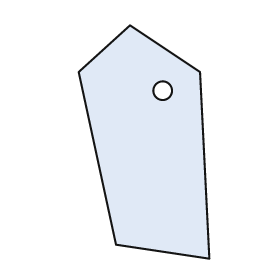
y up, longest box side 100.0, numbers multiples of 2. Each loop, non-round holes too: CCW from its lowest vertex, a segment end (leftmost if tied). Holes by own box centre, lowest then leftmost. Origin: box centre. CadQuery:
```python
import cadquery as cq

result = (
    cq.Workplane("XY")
    .moveTo(28.0, -50.0)
    .lineTo(24.0, 30.0)
    .lineTo(-6.0, 50.0)
    .lineTo(-28.0, 30.0)
    .lineTo(-12.0, -44.0)
    .close()
    .moveTo(8.0, 22.0)
    .circle(4.0)
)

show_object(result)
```